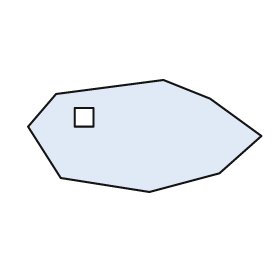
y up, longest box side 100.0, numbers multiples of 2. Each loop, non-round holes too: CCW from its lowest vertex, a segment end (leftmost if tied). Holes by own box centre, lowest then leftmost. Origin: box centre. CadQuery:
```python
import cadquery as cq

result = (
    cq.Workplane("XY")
    .moveTo(2.0, -24.0)
    .lineTo(32.0, -16.0)
    .lineTo(50.0, 0.0)
    .lineTo(28.0, 16.0)
    .lineTo(8.0, 24.0)
    .lineTo(-38.0, 18.0)
    .lineTo(-50.0, 4.0)
    .lineTo(-36.0, -18.0)
    .close()
    .moveTo(-30.0, 4.0)
    .lineTo(-22.0, 4.0)
    .lineTo(-22.0, 12.0)
    .lineTo(-30.0, 12.0)
    .close()
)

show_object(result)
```